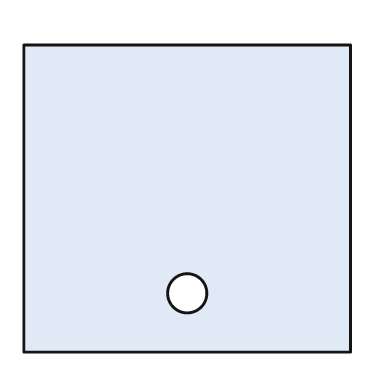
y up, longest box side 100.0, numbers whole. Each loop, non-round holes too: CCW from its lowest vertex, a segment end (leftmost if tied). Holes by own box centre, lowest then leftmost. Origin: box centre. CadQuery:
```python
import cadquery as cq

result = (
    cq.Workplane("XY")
    .moveTo(-50.0, -47.0)
    .lineTo(50.0, -47.0)
    .lineTo(50.0, 47.0)
    .lineTo(-50.0, 47.0)
    .close()
    .moveTo(0.0, -29.0)
    .circle(6.0)
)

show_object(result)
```